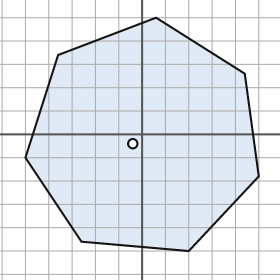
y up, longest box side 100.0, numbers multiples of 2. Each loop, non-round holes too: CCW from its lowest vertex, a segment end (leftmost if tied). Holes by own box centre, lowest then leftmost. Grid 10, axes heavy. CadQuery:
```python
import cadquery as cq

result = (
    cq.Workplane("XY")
    .moveTo(20.0, -50.0)
    .lineTo(50.0, -18.0)
    .lineTo(44.0, 26.0)
    .lineTo(6.0, 50.0)
    .lineTo(-36.0, 34.0)
    .lineTo(-50.0, -10.0)
    .lineTo(-26.0, -46.0)
    .close()
    .moveTo(-4.0, -4.0)
    .circle(2.0)
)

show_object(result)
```